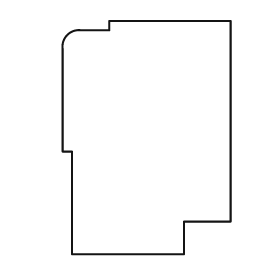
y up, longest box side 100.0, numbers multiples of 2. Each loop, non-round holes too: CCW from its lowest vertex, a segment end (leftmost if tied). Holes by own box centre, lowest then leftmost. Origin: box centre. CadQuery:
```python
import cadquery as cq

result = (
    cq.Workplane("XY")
    .moveTo(-32.0, -50.0)
    .lineTo(16.0, -50.0)
    .lineTo(16.0, -36.0)
    .lineTo(36.0, -36.0)
    .lineTo(36.0, 50.0)
    .lineTo(-16.0, 50.0)
    .lineTo(-16.0, 46.0)
    .lineTo(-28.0, 46.0)
    .threePointArc((-34.0, 44.0), (-36.0, 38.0))
    .lineTo(-36.0, -6.0)
    .lineTo(-32.0, -6.0)
    .close()
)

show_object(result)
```